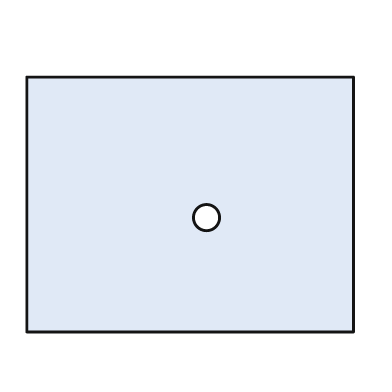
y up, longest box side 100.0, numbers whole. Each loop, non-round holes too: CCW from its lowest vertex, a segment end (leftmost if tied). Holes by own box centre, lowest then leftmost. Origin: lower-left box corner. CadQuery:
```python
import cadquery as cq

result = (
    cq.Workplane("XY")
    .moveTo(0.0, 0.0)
    .lineTo(100.0, 0.0)
    .lineTo(100.0, 78.0)
    .lineTo(0.0, 78.0)
    .close()
    .moveTo(55.0, 35.0)
    .circle(4.0)
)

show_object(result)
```